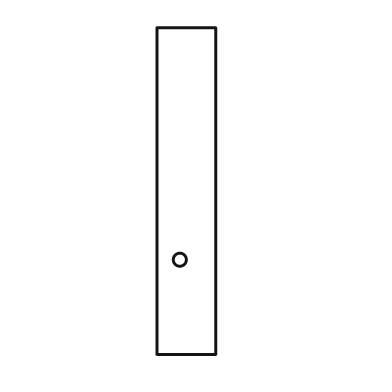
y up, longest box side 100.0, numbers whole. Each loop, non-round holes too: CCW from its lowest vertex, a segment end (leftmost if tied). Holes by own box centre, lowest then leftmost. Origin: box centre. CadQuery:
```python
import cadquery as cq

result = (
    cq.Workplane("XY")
    .moveTo(-9.0, -50.0)
    .lineTo(9.0, -50.0)
    .lineTo(9.0, 50.0)
    .lineTo(-9.0, 50.0)
    .close()
    .moveTo(-2.0, -21.0)
    .circle(2.0)
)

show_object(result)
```